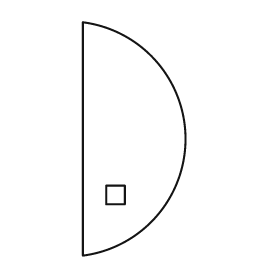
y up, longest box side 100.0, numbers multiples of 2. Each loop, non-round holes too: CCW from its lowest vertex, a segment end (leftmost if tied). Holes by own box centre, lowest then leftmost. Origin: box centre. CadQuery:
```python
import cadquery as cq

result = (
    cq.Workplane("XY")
    .moveTo(-22.0, -50.0)
    .threePointArc((22.0, 0.0), (-22.0, 50.0))
    .close()
    .moveTo(-12.0, -28.0)
    .lineTo(-4.0, -28.0)
    .lineTo(-4.0, -20.0)
    .lineTo(-12.0, -20.0)
    .close()
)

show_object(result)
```